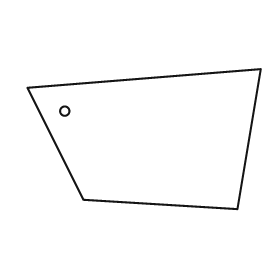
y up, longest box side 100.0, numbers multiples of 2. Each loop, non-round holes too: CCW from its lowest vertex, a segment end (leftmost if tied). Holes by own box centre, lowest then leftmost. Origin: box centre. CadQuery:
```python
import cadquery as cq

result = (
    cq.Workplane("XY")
    .moveTo(40.0, -30.0)
    .lineTo(50.0, 30.0)
    .lineTo(-50.0, 22.0)
    .lineTo(-26.0, -26.0)
    .close()
    .moveTo(-34.0, 12.0)
    .circle(2.0)
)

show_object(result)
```